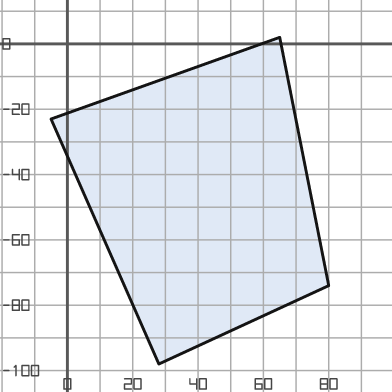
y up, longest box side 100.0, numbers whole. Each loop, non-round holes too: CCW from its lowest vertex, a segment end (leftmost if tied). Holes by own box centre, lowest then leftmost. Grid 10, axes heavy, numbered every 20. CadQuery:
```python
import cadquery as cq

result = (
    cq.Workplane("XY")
    .moveTo(28.0, -98.0)
    .lineTo(80.0, -74.0)
    .lineTo(65.0, 2.0)
    .lineTo(-5.0, -23.0)
    .close()
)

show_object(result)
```